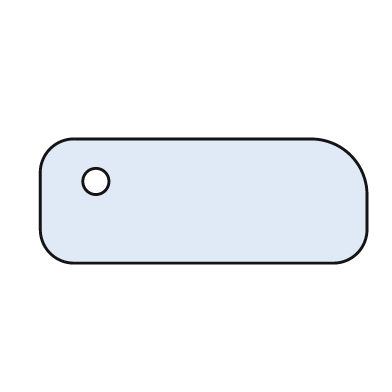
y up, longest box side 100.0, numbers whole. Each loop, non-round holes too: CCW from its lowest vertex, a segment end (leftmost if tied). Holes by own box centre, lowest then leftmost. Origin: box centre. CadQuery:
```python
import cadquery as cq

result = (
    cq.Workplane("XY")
    .moveTo(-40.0, -19.0)
    .lineTo(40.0, -19.0)
    .threePointArc((47.0, -16.0), (50.0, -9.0))
    .lineTo(50.0, 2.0)
    .threePointArc((45.0, 14.0), (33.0, 19.0))
    .lineTo(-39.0, 19.0)
    .threePointArc((-47.0, 16.0), (-50.0, 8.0))
    .lineTo(-50.0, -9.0)
    .threePointArc((-47.0, -16.0), (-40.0, -19.0))
    .close()
    .moveTo(-33.0, 6.0)
    .circle(4.0)
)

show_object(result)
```